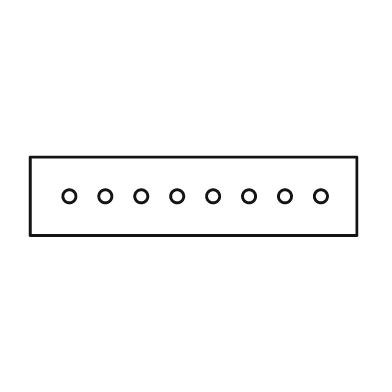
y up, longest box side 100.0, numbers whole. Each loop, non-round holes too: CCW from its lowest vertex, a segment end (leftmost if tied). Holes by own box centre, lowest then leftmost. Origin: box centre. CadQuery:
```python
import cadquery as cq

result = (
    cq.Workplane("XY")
    .moveTo(-50.0, -12.0)
    .lineTo(50.0, -12.0)
    .lineTo(50.0, 12.0)
    .lineTo(-50.0, 12.0)
    .close()
    .moveTo(-38.0, 0.0)
    .circle(2.0)
    .moveTo(-27.0, 0.0)
    .circle(2.0)
    .moveTo(-16.0, 0.0)
    .circle(2.0)
    .moveTo(-5.0, 0.0)
    .circle(2.0)
    .moveTo(6.0, 0.0)
    .circle(2.0)
    .moveTo(17.0, 0.0)
    .circle(2.0)
    .moveTo(28.0, 0.0)
    .circle(2.0)
    .moveTo(39.0, 0.0)
    .circle(2.0)
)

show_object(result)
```